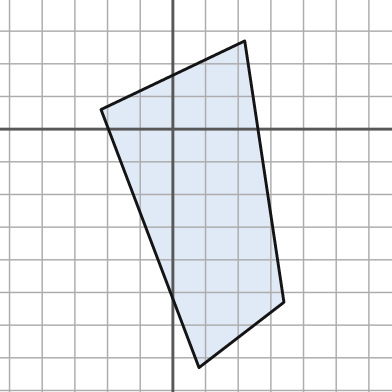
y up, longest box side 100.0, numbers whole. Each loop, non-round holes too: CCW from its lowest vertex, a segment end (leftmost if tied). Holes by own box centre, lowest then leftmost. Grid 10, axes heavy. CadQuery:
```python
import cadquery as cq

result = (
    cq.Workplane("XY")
    .moveTo(8.0, -73.0)
    .lineTo(34.0, -53.0)
    .lineTo(22.0, 27.0)
    .lineTo(-22.0, 6.0)
    .close()
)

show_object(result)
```